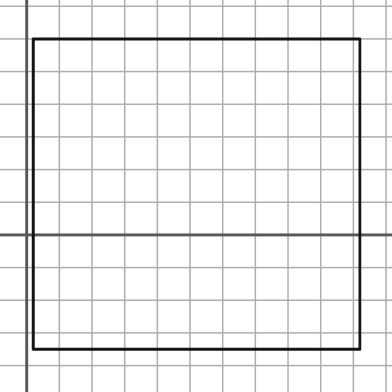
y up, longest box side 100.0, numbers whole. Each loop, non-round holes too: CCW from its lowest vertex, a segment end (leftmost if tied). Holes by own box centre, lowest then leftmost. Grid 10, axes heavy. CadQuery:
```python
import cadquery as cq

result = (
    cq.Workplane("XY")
    .moveTo(2.0, -35.0)
    .lineTo(102.0, -35.0)
    .lineTo(102.0, 60.0)
    .lineTo(2.0, 60.0)
    .close()
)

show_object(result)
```